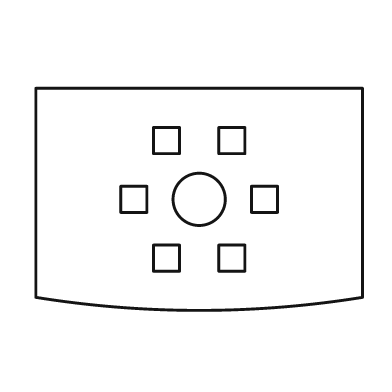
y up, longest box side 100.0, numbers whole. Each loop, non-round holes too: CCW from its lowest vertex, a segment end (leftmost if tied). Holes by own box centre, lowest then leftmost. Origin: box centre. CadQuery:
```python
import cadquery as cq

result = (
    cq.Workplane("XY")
    .moveTo(-50.0, -30.0)
    .threePointArc((0.0, -34.0), (50.0, -30.0))
    .lineTo(50.0, 34.0)
    .lineTo(-50.0, 34.0)
    .close()
    .moveTo(-14.0, -22.0)
    .lineTo(-6.0, -22.0)
    .lineTo(-6.0, -14.0)
    .lineTo(-14.0, -14.0)
    .close()
    .moveTo(6.0, -22.0)
    .lineTo(14.0, -22.0)
    .lineTo(14.0, -14.0)
    .lineTo(6.0, -14.0)
    .close()
    .moveTo(-24.0, -4.0)
    .lineTo(-16.0, -4.0)
    .lineTo(-16.0, 4.0)
    .lineTo(-24.0, 4.0)
    .close()
    .moveTo(0.0, 0.0)
    .circle(8.0)
    .moveTo(16.0, -4.0)
    .lineTo(24.0, -4.0)
    .lineTo(24.0, 4.0)
    .lineTo(16.0, 4.0)
    .close()
    .moveTo(-14.0, 14.0)
    .lineTo(-6.0, 14.0)
    .lineTo(-6.0, 22.0)
    .lineTo(-14.0, 22.0)
    .close()
    .moveTo(6.0, 14.0)
    .lineTo(14.0, 14.0)
    .lineTo(14.0, 22.0)
    .lineTo(6.0, 22.0)
    .close()
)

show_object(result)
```